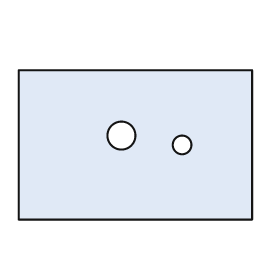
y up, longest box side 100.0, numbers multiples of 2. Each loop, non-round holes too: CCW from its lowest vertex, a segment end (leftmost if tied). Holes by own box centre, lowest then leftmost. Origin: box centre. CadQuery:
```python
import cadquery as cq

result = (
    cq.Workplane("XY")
    .moveTo(-50.0, -32.0)
    .lineTo(50.0, -32.0)
    .lineTo(50.0, 32.0)
    .lineTo(-50.0, 32.0)
    .close()
    .moveTo(20.0, 0.0)
    .circle(4.0)
    .moveTo(-6.0, 4.0)
    .circle(6.0)
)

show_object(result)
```